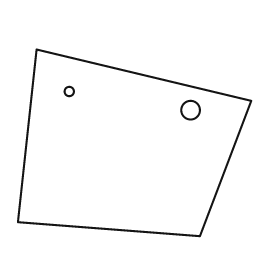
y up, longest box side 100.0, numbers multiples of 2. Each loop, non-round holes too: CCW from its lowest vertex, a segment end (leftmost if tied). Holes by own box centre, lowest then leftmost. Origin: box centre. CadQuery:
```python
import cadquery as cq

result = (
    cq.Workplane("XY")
    .moveTo(28.0, -40.0)
    .lineTo(50.0, 18.0)
    .lineTo(-42.0, 40.0)
    .lineTo(-50.0, -34.0)
    .close()
    .moveTo(24.0, 14.0)
    .circle(4.0)
    .moveTo(-28.0, 22.0)
    .circle(2.0)
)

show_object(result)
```